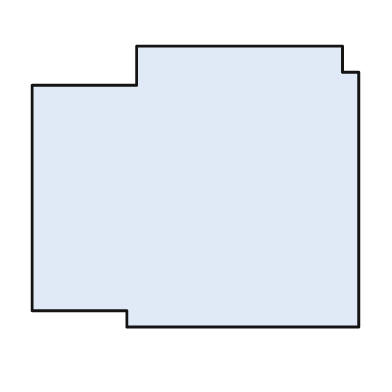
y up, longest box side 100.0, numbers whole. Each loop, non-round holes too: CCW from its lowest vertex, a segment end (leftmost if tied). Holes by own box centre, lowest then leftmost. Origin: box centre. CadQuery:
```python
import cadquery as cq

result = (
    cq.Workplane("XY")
    .moveTo(-21.0, -43.0)
    .lineTo(50.0, -43.0)
    .lineTo(50.0, 35.0)
    .lineTo(45.0, 35.0)
    .lineTo(45.0, 43.0)
    .lineTo(-18.0, 43.0)
    .lineTo(-18.0, 31.0)
    .lineTo(-50.0, 31.0)
    .lineTo(-50.0, -38.0)
    .lineTo(-21.0, -38.0)
    .close()
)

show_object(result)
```